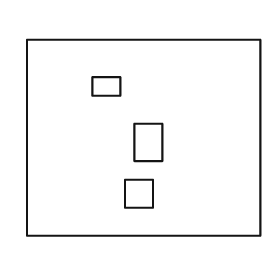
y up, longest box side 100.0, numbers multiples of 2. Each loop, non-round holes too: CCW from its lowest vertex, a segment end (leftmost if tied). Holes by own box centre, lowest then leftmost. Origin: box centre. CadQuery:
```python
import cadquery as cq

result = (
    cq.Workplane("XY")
    .moveTo(-50.0, -42.0)
    .lineTo(50.0, -42.0)
    .lineTo(50.0, 42.0)
    .lineTo(-50.0, 42.0)
    .close()
    .moveTo(-8.0, -30.0)
    .lineTo(4.0, -30.0)
    .lineTo(4.0, -18.0)
    .lineTo(-8.0, -18.0)
    .close()
    .moveTo(-4.0, -10.0)
    .lineTo(8.0, -10.0)
    .lineTo(8.0, 6.0)
    .lineTo(-4.0, 6.0)
    .close()
    .moveTo(-22.0, 18.0)
    .lineTo(-10.0, 18.0)
    .lineTo(-10.0, 26.0)
    .lineTo(-22.0, 26.0)
    .close()
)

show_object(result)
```